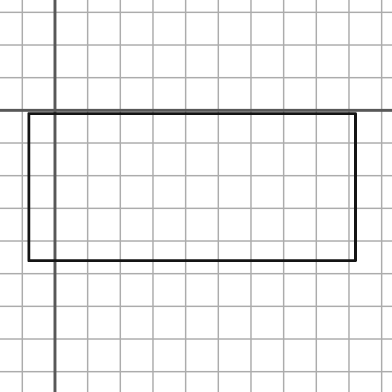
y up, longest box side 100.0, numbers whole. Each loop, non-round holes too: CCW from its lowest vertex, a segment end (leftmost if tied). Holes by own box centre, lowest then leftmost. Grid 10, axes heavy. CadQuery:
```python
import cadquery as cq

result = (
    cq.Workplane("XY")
    .moveTo(-8.0, -46.0)
    .lineTo(92.0, -46.0)
    .lineTo(92.0, -1.0)
    .lineTo(-8.0, -1.0)
    .close()
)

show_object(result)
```